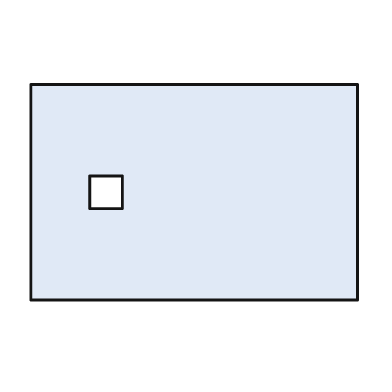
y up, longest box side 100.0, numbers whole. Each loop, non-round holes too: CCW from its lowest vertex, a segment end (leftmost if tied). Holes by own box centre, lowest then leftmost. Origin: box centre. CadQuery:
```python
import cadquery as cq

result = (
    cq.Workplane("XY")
    .moveTo(-50.0, -33.0)
    .lineTo(50.0, -33.0)
    .lineTo(50.0, 33.0)
    .lineTo(-50.0, 33.0)
    .close()
    .moveTo(-32.0, -5.0)
    .lineTo(-22.0, -5.0)
    .lineTo(-22.0, 5.0)
    .lineTo(-32.0, 5.0)
    .close()
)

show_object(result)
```